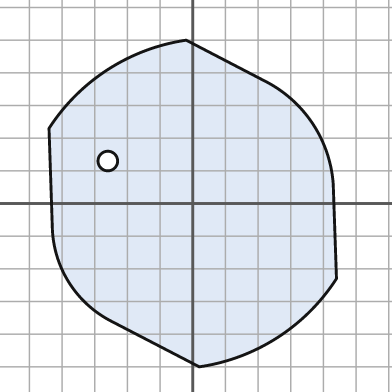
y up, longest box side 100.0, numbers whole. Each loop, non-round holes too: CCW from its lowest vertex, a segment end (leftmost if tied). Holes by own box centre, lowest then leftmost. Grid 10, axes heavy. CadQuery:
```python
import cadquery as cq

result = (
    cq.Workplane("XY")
    .moveTo(2.0, -50.0)
    .threePointArc((26.0, -41.0), (44.0, -23.0))
    .lineTo(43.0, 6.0)
    .threePointArc((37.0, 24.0), (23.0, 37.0))
    .lineTo(-2.0, 50.0)
    .threePointArc((-26.0, 41.0), (-44.0, 23.0))
    .lineTo(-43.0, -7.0)
    .threePointArc((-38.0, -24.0), (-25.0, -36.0))
    .close()
    .moveTo(-26.0, 13.0)
    .circle(3.0)
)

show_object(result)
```